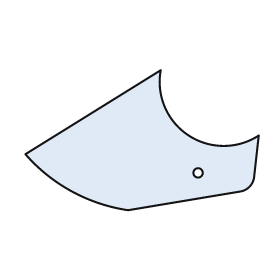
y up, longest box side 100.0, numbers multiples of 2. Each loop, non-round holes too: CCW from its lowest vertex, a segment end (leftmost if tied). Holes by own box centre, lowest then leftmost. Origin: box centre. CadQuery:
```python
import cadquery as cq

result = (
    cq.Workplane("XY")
    .moveTo(-6.0, -30.0)
    .lineTo(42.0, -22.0)
    .threePointArc((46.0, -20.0), (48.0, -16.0))
    .lineTo(50.0, 2.0)
    .threePointArc((20.0, 2.0), (8.0, 30.0))
    .lineTo(-50.0, -6.0)
    .threePointArc((-30.0, -22.0), (-6.0, -30.0))
    .close()
    .moveTo(24.0, -14.0)
    .circle(2.0)
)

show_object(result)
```